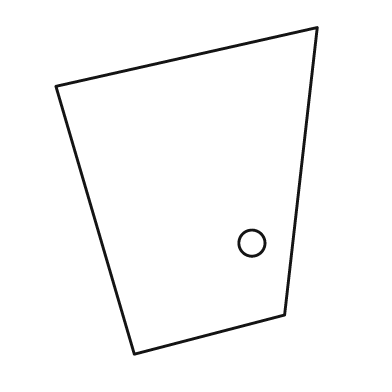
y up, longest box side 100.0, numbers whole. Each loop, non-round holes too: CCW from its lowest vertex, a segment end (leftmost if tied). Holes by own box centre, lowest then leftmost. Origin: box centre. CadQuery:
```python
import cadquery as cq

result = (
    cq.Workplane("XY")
    .moveTo(-16.0, -50.0)
    .lineTo(30.0, -38.0)
    .lineTo(40.0, 50.0)
    .lineTo(-40.0, 32.0)
    .close()
    .moveTo(20.0, -16.0)
    .circle(4.0)
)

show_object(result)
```